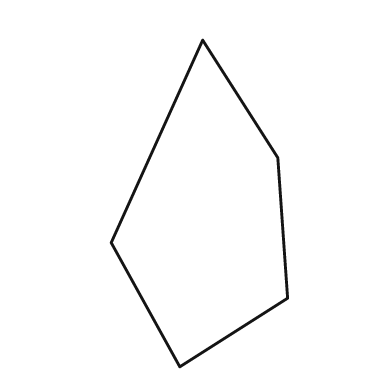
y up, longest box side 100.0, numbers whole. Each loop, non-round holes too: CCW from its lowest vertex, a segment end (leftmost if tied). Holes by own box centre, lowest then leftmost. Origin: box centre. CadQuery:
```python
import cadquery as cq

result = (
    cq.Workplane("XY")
    .moveTo(-6.0, -50.0)
    .lineTo(27.0, -29.0)
    .lineTo(24.0, 14.0)
    .lineTo(1.0, 50.0)
    .lineTo(-27.0, -12.0)
    .close()
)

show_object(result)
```